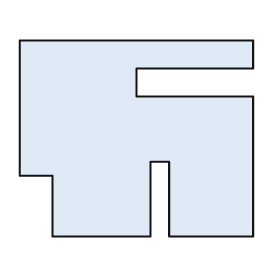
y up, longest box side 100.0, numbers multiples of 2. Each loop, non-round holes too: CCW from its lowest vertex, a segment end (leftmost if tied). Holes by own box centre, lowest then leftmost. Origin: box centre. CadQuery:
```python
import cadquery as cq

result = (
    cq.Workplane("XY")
    .moveTo(-36.0, -42.0)
    .lineTo(6.0, -42.0)
    .lineTo(6.0, -10.0)
    .lineTo(14.0, -10.0)
    .lineTo(14.0, -42.0)
    .lineTo(50.0, -42.0)
    .lineTo(50.0, 18.0)
    .lineTo(0.0, 18.0)
    .lineTo(0.0, 30.0)
    .lineTo(50.0, 30.0)
    .lineTo(50.0, 42.0)
    .lineTo(-50.0, 42.0)
    .lineTo(-50.0, -16.0)
    .lineTo(-36.0, -16.0)
    .close()
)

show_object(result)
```